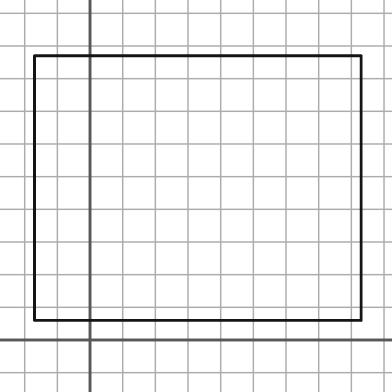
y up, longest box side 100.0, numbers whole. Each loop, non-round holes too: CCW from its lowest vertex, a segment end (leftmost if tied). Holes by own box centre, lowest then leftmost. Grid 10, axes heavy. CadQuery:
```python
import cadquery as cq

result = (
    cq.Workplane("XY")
    .moveTo(-17.0, 6.0)
    .lineTo(83.0, 6.0)
    .lineTo(83.0, 87.0)
    .lineTo(-17.0, 87.0)
    .close()
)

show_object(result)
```